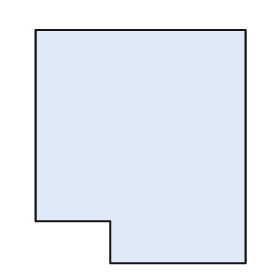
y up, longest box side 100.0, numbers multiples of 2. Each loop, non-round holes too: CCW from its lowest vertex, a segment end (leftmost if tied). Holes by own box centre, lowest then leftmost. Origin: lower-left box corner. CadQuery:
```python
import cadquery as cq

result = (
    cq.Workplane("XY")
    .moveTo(32.0, 0.0)
    .lineTo(90.0, 0.0)
    .lineTo(90.0, 100.0)
    .lineTo(0.0, 100.0)
    .lineTo(0.0, 18.0)
    .lineTo(32.0, 18.0)
    .close()
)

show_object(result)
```